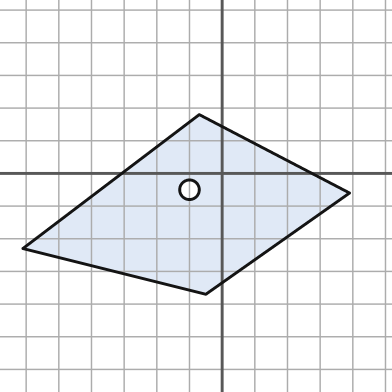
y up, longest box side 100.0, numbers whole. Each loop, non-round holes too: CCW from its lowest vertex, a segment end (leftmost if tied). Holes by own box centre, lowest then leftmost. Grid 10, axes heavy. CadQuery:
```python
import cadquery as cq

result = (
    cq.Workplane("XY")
    .moveTo(-5.0, -37.0)
    .lineTo(39.0, -6.0)
    .lineTo(-7.0, 18.0)
    .lineTo(-61.0, -23.0)
    .close()
    .moveTo(-10.0, -5.0)
    .circle(3.0)
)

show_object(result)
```